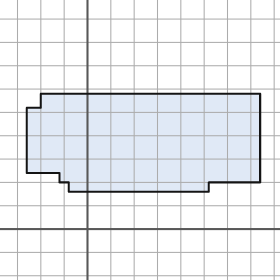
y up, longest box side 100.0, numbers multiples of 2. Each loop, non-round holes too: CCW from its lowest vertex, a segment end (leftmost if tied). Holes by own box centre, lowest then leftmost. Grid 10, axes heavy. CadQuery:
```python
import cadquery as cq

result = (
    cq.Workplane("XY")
    .moveTo(-8.0, 16.0)
    .lineTo(52.0, 16.0)
    .lineTo(52.0, 20.0)
    .lineTo(74.0, 20.0)
    .lineTo(74.0, 58.0)
    .lineTo(-20.0, 58.0)
    .lineTo(-20.0, 52.0)
    .lineTo(-26.0, 52.0)
    .lineTo(-26.0, 24.0)
    .lineTo(-12.0, 24.0)
    .lineTo(-12.0, 20.0)
    .lineTo(-8.0, 20.0)
    .close()
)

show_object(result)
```